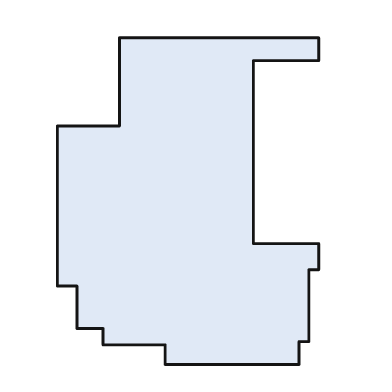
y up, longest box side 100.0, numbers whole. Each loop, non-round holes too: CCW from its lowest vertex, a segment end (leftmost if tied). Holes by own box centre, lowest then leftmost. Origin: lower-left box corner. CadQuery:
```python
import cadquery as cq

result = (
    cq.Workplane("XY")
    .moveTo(33.0, 0.0)
    .lineTo(74.0, 0.0)
    .lineTo(74.0, 7.0)
    .lineTo(77.0, 7.0)
    .lineTo(77.0, 29.0)
    .lineTo(80.0, 29.0)
    .lineTo(80.0, 37.0)
    .lineTo(60.0, 37.0)
    .lineTo(60.0, 93.0)
    .lineTo(80.0, 93.0)
    .lineTo(80.0, 100.0)
    .lineTo(19.0, 100.0)
    .lineTo(19.0, 73.0)
    .lineTo(0.0, 73.0)
    .lineTo(0.0, 24.0)
    .lineTo(6.0, 24.0)
    .lineTo(6.0, 11.0)
    .lineTo(14.0, 11.0)
    .lineTo(14.0, 6.0)
    .lineTo(33.0, 6.0)
    .close()
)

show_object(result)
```